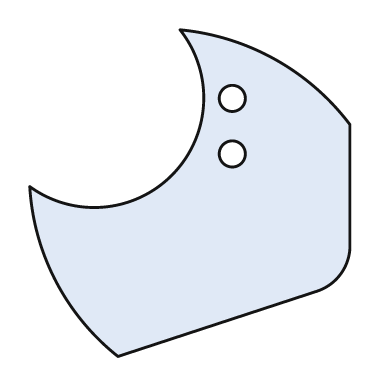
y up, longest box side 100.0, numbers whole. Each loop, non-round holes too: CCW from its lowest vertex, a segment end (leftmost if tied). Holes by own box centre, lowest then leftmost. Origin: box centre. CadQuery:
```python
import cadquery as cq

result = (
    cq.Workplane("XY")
    .moveTo(-22.0, -50.0)
    .lineTo(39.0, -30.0)
    .threePointArc((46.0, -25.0), (49.0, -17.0))
    .lineTo(49.0, 21.0)
    .threePointArc((26.0, 41.0), (-3.0, 50.0))
    .threePointArc((-5.0, 6.0), (-49.0, 2.0))
    .threePointArc((-41.0, -27.0), (-22.0, -50.0))
    .close()
    .moveTo(13.0, 12.0)
    .circle(4.0)
    .moveTo(13.0, 29.0)
    .circle(4.0)
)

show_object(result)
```